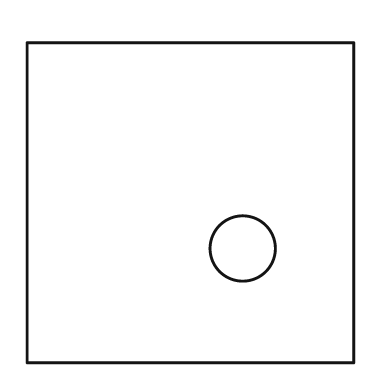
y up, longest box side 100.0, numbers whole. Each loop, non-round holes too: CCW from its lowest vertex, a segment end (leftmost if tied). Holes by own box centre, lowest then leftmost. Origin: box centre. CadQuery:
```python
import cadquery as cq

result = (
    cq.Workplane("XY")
    .moveTo(-50.0, -49.0)
    .lineTo(50.0, -49.0)
    .lineTo(50.0, 49.0)
    .lineTo(-50.0, 49.0)
    .close()
    .moveTo(16.0, -14.0)
    .circle(10.0)
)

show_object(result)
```